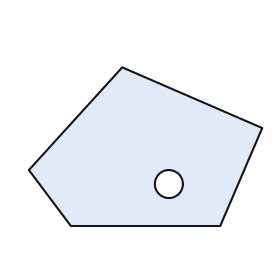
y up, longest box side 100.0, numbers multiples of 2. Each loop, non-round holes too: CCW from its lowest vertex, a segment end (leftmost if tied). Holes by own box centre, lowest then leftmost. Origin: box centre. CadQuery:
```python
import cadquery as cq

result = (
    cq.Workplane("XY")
    .moveTo(-32.0, -34.0)
    .lineTo(32.0, -34.0)
    .lineTo(50.0, 8.0)
    .lineTo(-10.0, 34.0)
    .lineTo(-50.0, -10.0)
    .close()
    .moveTo(10.0, -16.0)
    .circle(6.0)
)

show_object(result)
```